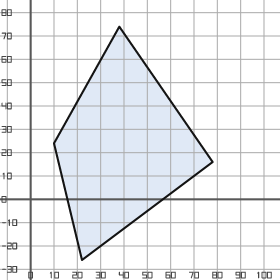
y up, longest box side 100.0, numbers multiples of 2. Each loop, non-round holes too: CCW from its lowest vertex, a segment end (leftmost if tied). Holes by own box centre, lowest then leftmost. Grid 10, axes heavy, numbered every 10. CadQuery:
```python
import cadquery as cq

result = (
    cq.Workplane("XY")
    .moveTo(22.0, -26.0)
    .lineTo(78.0, 16.0)
    .lineTo(38.0, 74.0)
    .lineTo(10.0, 24.0)
    .close()
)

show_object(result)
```